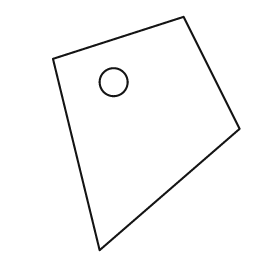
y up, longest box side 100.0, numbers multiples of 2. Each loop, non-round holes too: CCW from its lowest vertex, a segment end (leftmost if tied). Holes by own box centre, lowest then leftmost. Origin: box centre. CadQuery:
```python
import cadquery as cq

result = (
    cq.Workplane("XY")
    .moveTo(-20.0, -50.0)
    .lineTo(40.0, 2.0)
    .lineTo(16.0, 50.0)
    .lineTo(-40.0, 32.0)
    .close()
    .moveTo(-14.0, 22.0)
    .circle(6.0)
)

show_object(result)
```